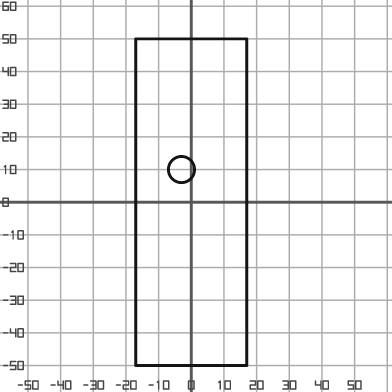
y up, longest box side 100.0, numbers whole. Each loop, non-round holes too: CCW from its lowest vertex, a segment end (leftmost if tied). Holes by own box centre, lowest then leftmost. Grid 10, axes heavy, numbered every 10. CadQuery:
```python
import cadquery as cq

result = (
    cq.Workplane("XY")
    .moveTo(-17.0, -50.0)
    .lineTo(17.0, -50.0)
    .lineTo(17.0, 50.0)
    .lineTo(-17.0, 50.0)
    .close()
    .moveTo(-3.0, 10.0)
    .circle(4.0)
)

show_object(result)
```